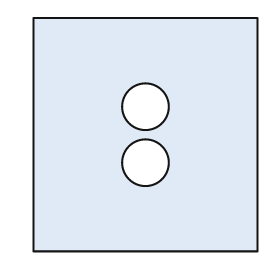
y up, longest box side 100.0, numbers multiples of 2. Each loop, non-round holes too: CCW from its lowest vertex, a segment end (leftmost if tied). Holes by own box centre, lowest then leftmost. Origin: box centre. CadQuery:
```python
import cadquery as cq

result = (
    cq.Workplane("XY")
    .moveTo(-48.0, -50.0)
    .lineTo(48.0, -50.0)
    .lineTo(48.0, 50.0)
    .lineTo(-48.0, 50.0)
    .close()
    .moveTo(0.0, -12.0)
    .circle(10.0)
    .moveTo(0.0, 12.0)
    .circle(10.0)
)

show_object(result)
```